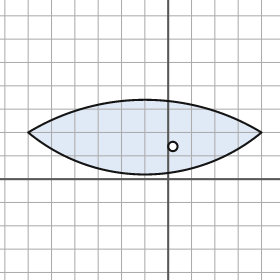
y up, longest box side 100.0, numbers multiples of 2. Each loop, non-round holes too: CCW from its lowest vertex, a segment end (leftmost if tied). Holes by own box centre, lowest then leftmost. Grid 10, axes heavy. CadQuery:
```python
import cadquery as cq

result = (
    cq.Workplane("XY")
    .moveTo(-60.0, 20.0)
    .threePointArc((-10.0, 2.0), (40.0, 20.0))
    .threePointArc((-10.0, 34.0), (-60.0, 20.0))
    .close()
    .moveTo(2.0, 14.0)
    .circle(2.0)
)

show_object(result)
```